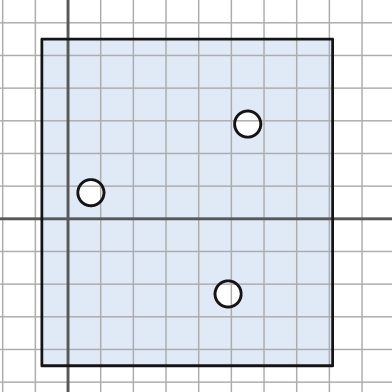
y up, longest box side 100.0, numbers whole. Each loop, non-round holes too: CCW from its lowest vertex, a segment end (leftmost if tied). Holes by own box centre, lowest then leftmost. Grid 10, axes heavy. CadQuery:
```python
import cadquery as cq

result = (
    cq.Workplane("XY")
    .moveTo(-8.0, -45.0)
    .lineTo(81.0, -45.0)
    .lineTo(81.0, 55.0)
    .lineTo(-8.0, 55.0)
    .close()
    .moveTo(49.0, -23.0)
    .circle(4.0)
    .moveTo(7.0, 8.0)
    .circle(4.0)
    .moveTo(55.0, 29.0)
    .circle(4.0)
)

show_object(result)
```